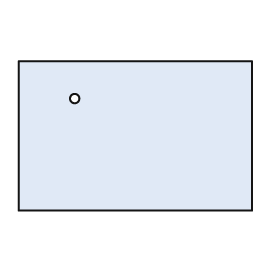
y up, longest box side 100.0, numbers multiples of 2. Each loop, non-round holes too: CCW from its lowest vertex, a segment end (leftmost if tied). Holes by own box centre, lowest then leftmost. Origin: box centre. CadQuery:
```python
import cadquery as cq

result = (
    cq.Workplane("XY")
    .moveTo(-50.0, -32.0)
    .lineTo(50.0, -32.0)
    .lineTo(50.0, 32.0)
    .lineTo(-50.0, 32.0)
    .close()
    .moveTo(-26.0, 16.0)
    .circle(2.0)
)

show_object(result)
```